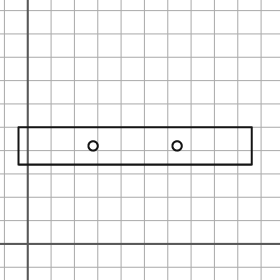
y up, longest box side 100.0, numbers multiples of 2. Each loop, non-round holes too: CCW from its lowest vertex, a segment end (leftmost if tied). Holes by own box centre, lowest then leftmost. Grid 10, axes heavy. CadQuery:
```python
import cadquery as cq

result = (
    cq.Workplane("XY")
    .moveTo(-4.0, 34.0)
    .lineTo(96.0, 34.0)
    .lineTo(96.0, 50.0)
    .lineTo(-4.0, 50.0)
    .close()
    .moveTo(28.0, 42.0)
    .circle(2.0)
    .moveTo(64.0, 42.0)
    .circle(2.0)
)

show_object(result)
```